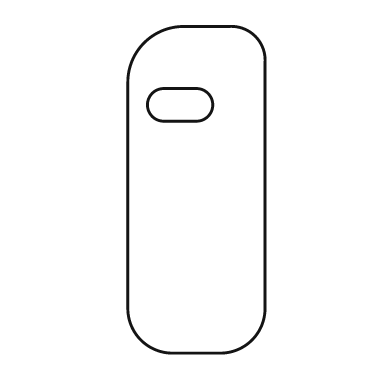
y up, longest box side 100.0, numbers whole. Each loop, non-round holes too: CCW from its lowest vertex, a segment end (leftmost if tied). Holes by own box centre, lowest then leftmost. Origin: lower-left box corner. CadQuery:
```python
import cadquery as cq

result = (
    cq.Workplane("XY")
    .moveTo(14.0, 0.0)
    .lineTo(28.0, 0.0)
    .threePointArc((38.0, 4.0), (42.0, 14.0))
    .lineTo(42.0, 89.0)
    .threePointArc((39.0, 97.0), (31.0, 100.0))
    .lineTo(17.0, 100.0)
    .threePointArc((5.0, 95.0), (0.0, 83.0))
    .lineTo(0.0, 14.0)
    .threePointArc((4.0, 4.0), (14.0, 0.0))
    .close()
    .moveTo(11.0, 71.0)
    .lineTo(21.0, 71.0)
    .threePointArc((26.0, 76.0), (21.0, 81.0))
    .lineTo(11.0, 81.0)
    .threePointArc((6.0, 76.0), (11.0, 71.0))
    .close()
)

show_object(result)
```